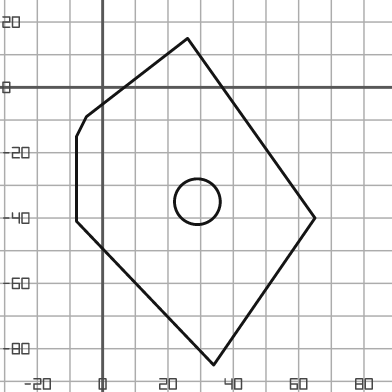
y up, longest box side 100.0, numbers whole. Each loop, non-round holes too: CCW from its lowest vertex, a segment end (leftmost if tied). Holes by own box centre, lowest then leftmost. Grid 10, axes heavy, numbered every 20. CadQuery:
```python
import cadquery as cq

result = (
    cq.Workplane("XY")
    .moveTo(34.0, -85.0)
    .lineTo(65.0, -40.0)
    .lineTo(26.0, 15.0)
    .lineTo(-5.0, -9.0)
    .lineTo(-8.0, -15.0)
    .lineTo(-8.0, -41.0)
    .close()
    .moveTo(29.0, -35.0)
    .circle(7.0)
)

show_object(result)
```